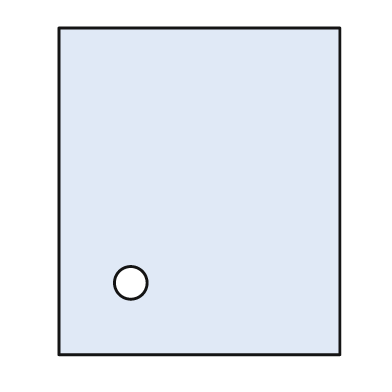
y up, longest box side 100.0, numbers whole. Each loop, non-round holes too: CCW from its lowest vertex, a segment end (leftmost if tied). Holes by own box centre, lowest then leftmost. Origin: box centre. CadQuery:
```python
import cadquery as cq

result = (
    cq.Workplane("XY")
    .moveTo(-43.0, -50.0)
    .lineTo(43.0, -50.0)
    .lineTo(43.0, 50.0)
    .lineTo(-43.0, 50.0)
    .close()
    .moveTo(-21.0, -28.0)
    .circle(5.0)
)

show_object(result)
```